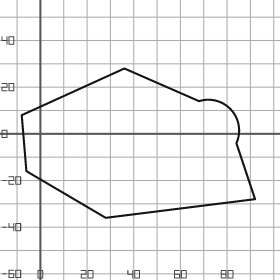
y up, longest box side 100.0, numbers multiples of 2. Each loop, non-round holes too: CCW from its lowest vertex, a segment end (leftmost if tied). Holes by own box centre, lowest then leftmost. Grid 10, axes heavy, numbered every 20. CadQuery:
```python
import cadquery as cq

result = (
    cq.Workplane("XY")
    .moveTo(28.0, -36.0)
    .lineTo(92.0, -28.0)
    .lineTo(84.0, -4.0)
    .threePointArc((82.0, 10.0), (68.0, 14.0))
    .lineTo(36.0, 28.0)
    .lineTo(-8.0, 8.0)
    .lineTo(-6.0, -16.0)
    .close()
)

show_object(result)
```